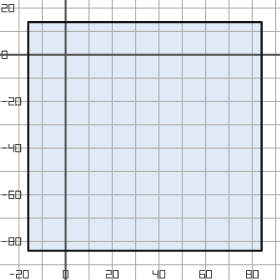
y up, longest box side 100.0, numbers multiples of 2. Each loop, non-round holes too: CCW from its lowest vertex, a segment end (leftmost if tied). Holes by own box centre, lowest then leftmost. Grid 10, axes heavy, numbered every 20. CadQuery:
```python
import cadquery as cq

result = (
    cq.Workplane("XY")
    .moveTo(-16.0, -84.0)
    .lineTo(84.0, -84.0)
    .lineTo(84.0, 14.0)
    .lineTo(-16.0, 14.0)
    .close()
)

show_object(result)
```